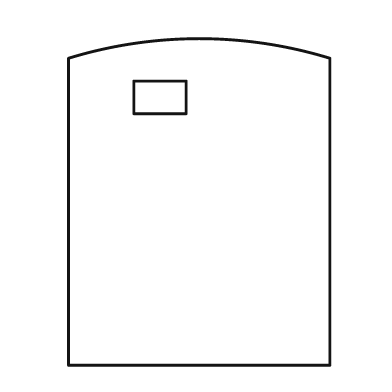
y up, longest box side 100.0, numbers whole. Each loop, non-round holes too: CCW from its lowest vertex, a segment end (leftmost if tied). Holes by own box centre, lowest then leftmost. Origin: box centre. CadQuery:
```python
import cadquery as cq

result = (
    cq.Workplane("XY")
    .moveTo(-40.0, -50.0)
    .lineTo(40.0, -50.0)
    .lineTo(40.0, 44.0)
    .threePointArc((0.0, 50.0), (-40.0, 44.0))
    .close()
    .moveTo(-20.0, 27.0)
    .lineTo(-4.0, 27.0)
    .lineTo(-4.0, 37.0)
    .lineTo(-20.0, 37.0)
    .close()
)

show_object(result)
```